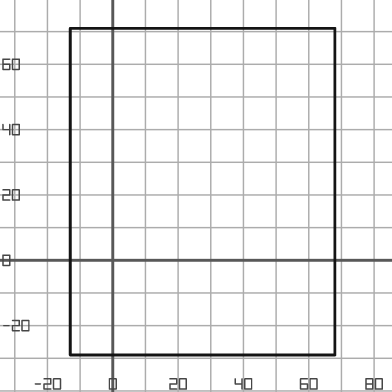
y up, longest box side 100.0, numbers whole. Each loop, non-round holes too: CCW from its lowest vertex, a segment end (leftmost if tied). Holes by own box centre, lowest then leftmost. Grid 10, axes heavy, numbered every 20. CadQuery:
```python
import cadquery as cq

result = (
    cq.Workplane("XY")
    .moveTo(-13.0, -29.0)
    .lineTo(68.0, -29.0)
    .lineTo(68.0, 71.0)
    .lineTo(-13.0, 71.0)
    .close()
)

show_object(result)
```